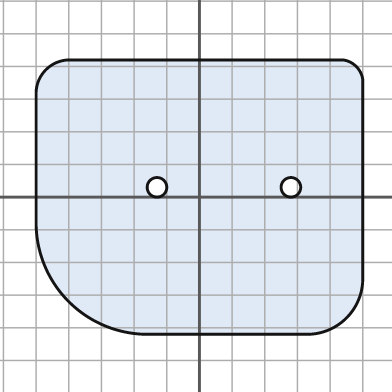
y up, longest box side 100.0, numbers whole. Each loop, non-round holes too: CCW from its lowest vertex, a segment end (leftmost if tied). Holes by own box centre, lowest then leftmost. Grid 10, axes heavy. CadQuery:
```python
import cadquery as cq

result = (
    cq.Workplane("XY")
    .moveTo(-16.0, -42.0)
    .lineTo(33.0, -42.0)
    .threePointArc((45.0, -37.0), (50.0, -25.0))
    .lineTo(50.0, 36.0)
    .threePointArc((48.0, 40.0), (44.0, 42.0))
    .lineTo(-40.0, 42.0)
    .threePointArc((-47.0, 39.0), (-50.0, 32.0))
    .lineTo(-50.0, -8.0)
    .threePointArc((-40.0, -32.0), (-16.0, -42.0))
    .close()
    .moveTo(-13.0, 3.0)
    .circle(3.0)
    .moveTo(28.0, 3.0)
    .circle(3.0)
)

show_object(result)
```